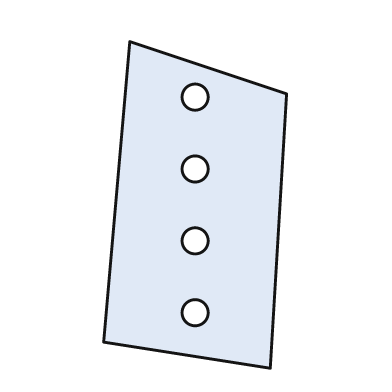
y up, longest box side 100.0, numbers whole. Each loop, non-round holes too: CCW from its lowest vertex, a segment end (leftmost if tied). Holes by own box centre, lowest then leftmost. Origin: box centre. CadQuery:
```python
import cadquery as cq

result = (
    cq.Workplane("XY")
    .moveTo(23.0, -50.0)
    .lineTo(28.0, 34.0)
    .lineTo(-20.0, 50.0)
    .lineTo(-28.0, -42.0)
    .close()
    .moveTo(0.0, -33.0)
    .circle(4.0)
    .moveTo(0.0, -11.0)
    .circle(4.0)
    .moveTo(0.0, 11.0)
    .circle(4.0)
    .moveTo(0.0, 33.0)
    .circle(4.0)
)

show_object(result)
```